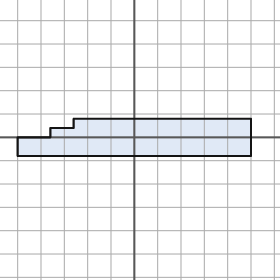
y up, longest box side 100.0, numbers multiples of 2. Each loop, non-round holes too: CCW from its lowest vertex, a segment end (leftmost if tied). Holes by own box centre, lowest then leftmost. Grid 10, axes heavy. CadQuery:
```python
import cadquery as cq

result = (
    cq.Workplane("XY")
    .moveTo(-50.0, -8.0)
    .lineTo(50.0, -8.0)
    .lineTo(50.0, 8.0)
    .lineTo(-26.0, 8.0)
    .lineTo(-26.0, 4.0)
    .lineTo(-36.0, 4.0)
    .lineTo(-36.0, 0.0)
    .lineTo(-50.0, 0.0)
    .close()
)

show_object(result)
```